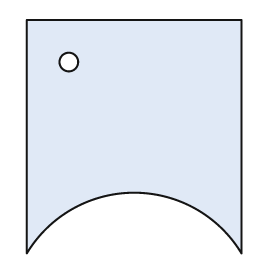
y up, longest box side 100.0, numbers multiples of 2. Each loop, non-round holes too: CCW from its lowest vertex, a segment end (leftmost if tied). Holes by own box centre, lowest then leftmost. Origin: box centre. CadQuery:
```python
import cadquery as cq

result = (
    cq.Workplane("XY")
    .moveTo(-46.0, -50.0)
    .threePointArc((0.0, -24.0), (46.0, -50.0))
    .lineTo(46.0, 50.0)
    .lineTo(-46.0, 50.0)
    .close()
    .moveTo(-28.0, 32.0)
    .circle(4.0)
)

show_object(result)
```